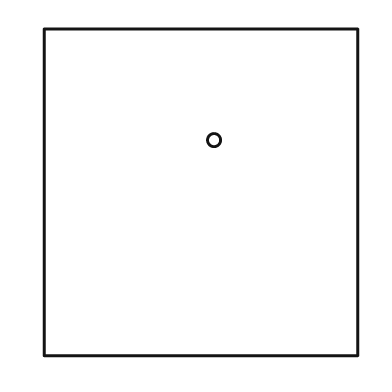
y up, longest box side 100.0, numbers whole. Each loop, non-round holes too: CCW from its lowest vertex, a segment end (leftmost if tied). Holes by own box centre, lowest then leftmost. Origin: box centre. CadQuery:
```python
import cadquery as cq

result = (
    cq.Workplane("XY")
    .moveTo(-48.0, -50.0)
    .lineTo(48.0, -50.0)
    .lineTo(48.0, 50.0)
    .lineTo(-48.0, 50.0)
    .close()
    .moveTo(4.0, 16.0)
    .circle(2.0)
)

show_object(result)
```